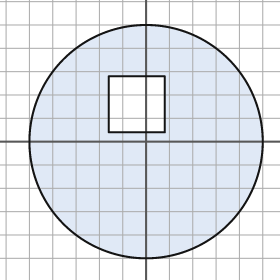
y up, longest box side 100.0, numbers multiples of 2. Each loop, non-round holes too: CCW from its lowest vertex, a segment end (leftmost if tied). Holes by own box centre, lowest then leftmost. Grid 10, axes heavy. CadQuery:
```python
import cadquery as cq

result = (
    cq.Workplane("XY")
    .moveTo(0.0, 0.0)
    .circle(50.0)
    .moveTo(-16.0, 4.0)
    .lineTo(8.0, 4.0)
    .lineTo(8.0, 28.0)
    .lineTo(-16.0, 28.0)
    .close()
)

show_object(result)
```